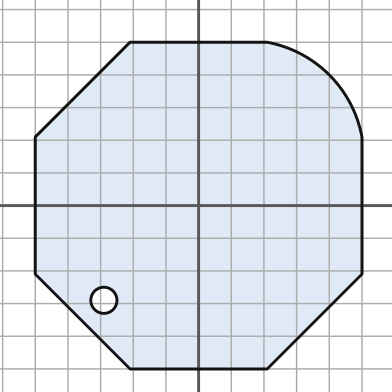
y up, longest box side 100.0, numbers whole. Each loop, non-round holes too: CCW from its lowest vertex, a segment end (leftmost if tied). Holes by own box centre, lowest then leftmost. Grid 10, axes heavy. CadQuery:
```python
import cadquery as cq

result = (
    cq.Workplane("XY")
    .moveTo(-21.0, -50.0)
    .lineTo(21.0, -50.0)
    .lineTo(50.0, -21.0)
    .lineTo(50.0, 21.0)
    .threePointArc((40.0, 40.0), (21.0, 50.0))
    .lineTo(-21.0, 50.0)
    .lineTo(-50.0, 21.0)
    .lineTo(-50.0, -21.0)
    .close()
    .moveTo(-29.0, -29.0)
    .circle(4.0)
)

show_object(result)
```